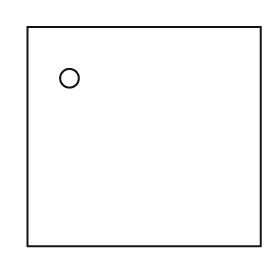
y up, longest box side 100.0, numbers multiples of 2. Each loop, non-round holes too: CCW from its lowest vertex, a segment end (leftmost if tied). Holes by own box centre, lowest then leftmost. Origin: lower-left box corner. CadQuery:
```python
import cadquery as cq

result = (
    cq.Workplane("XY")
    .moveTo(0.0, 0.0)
    .lineTo(100.0, 0.0)
    .lineTo(100.0, 94.0)
    .lineTo(0.0, 94.0)
    .close()
    .moveTo(18.0, 72.0)
    .circle(4.0)
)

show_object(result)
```